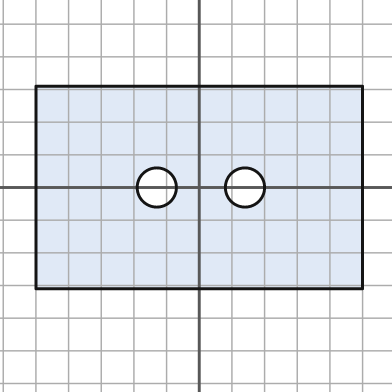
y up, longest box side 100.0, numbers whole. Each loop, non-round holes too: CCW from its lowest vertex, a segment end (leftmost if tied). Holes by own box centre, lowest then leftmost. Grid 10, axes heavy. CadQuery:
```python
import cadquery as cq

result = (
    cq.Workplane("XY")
    .moveTo(-50.0, -31.0)
    .lineTo(50.0, -31.0)
    .lineTo(50.0, 31.0)
    .lineTo(-50.0, 31.0)
    .close()
    .moveTo(-13.0, 0.0)
    .circle(6.0)
    .moveTo(14.0, 0.0)
    .circle(6.0)
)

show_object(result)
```